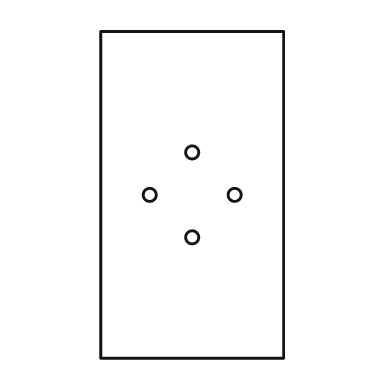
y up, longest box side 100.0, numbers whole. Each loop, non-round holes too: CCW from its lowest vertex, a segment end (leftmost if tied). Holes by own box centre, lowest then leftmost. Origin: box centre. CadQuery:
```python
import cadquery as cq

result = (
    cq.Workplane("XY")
    .moveTo(-28.0, -50.0)
    .lineTo(28.0, -50.0)
    .lineTo(28.0, 50.0)
    .lineTo(-28.0, 50.0)
    .close()
    .moveTo(0.0, -13.0)
    .circle(2.0)
    .moveTo(-13.0, 0.0)
    .circle(2.0)
    .moveTo(13.0, 0.0)
    .circle(2.0)
    .moveTo(0.0, 13.0)
    .circle(2.0)
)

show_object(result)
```